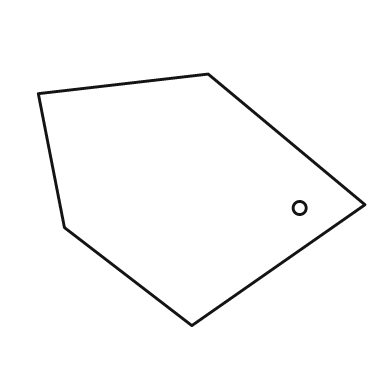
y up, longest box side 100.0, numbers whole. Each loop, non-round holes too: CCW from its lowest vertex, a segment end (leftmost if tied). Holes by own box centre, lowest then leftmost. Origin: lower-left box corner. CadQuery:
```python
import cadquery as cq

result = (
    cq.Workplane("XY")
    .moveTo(47.0, 0.0)
    .lineTo(100.0, 37.0)
    .lineTo(52.0, 77.0)
    .lineTo(0.0, 71.0)
    .lineTo(8.0, 30.0)
    .close()
    .moveTo(80.0, 36.0)
    .circle(2.0)
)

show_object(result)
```